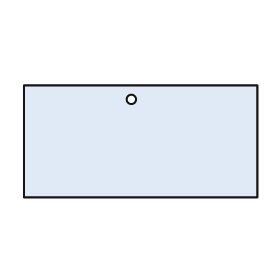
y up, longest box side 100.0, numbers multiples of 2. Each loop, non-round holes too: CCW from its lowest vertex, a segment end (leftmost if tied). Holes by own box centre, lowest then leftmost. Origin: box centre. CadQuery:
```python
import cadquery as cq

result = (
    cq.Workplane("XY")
    .moveTo(-50.0, -24.0)
    .lineTo(50.0, -24.0)
    .lineTo(50.0, 24.0)
    .lineTo(-50.0, 24.0)
    .close()
    .moveTo(-4.0, 18.0)
    .circle(2.0)
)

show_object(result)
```